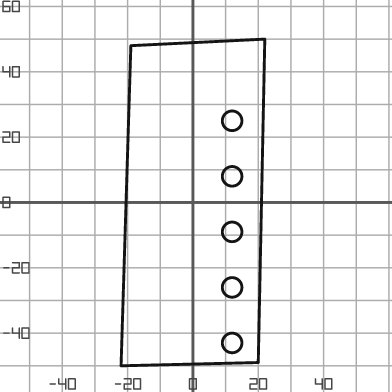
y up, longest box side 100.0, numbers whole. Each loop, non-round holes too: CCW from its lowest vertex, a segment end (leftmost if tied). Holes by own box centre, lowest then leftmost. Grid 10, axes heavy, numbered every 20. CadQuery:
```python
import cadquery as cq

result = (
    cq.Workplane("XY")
    .moveTo(-22.0, -50.0)
    .lineTo(20.0, -49.0)
    .lineTo(22.0, 50.0)
    .lineTo(-19.0, 48.0)
    .close()
    .moveTo(12.0, -43.0)
    .circle(3.0)
    .moveTo(12.0, -26.0)
    .circle(3.0)
    .moveTo(12.0, -9.0)
    .circle(3.0)
    .moveTo(12.0, 8.0)
    .circle(3.0)
    .moveTo(12.0, 25.0)
    .circle(3.0)
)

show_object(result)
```